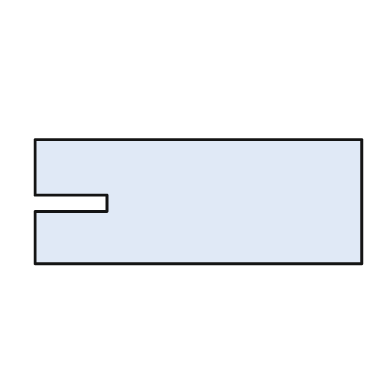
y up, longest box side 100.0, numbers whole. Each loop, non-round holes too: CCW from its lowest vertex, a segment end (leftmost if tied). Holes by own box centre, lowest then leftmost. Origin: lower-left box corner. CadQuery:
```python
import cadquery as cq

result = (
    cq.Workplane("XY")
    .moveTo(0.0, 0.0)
    .lineTo(100.0, 0.0)
    .lineTo(100.0, 38.0)
    .lineTo(0.0, 38.0)
    .lineTo(0.0, 21.0)
    .lineTo(22.0, 21.0)
    .lineTo(22.0, 16.0)
    .lineTo(0.0, 16.0)
    .close()
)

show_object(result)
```